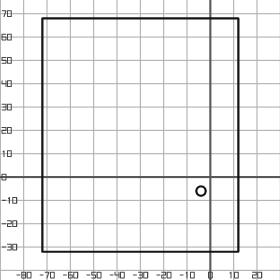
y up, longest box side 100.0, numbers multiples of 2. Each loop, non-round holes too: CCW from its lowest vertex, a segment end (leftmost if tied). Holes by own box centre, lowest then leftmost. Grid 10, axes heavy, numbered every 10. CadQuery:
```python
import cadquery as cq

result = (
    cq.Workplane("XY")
    .moveTo(-72.0, -32.0)
    .lineTo(12.0, -32.0)
    .lineTo(12.0, 68.0)
    .lineTo(-72.0, 68.0)
    .close()
    .moveTo(-4.0, -6.0)
    .circle(2.0)
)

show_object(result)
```